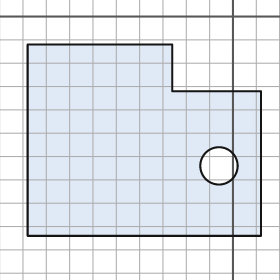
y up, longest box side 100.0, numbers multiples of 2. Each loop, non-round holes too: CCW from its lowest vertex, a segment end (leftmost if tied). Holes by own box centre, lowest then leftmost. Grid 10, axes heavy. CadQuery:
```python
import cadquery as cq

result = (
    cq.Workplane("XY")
    .moveTo(-88.0, -94.0)
    .lineTo(12.0, -94.0)
    .lineTo(12.0, -32.0)
    .lineTo(-26.0, -32.0)
    .lineTo(-26.0, -12.0)
    .lineTo(-88.0, -12.0)
    .close()
    .moveTo(-6.0, -64.0)
    .circle(8.0)
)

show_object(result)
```